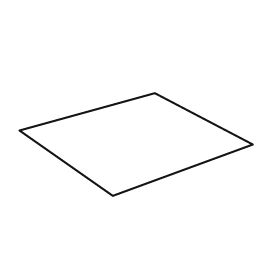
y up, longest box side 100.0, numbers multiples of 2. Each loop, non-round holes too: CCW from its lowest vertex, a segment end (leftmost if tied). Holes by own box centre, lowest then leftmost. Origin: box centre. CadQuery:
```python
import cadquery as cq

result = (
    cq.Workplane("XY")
    .moveTo(-10.0, -22.0)
    .lineTo(50.0, 0.0)
    .lineTo(8.0, 22.0)
    .lineTo(-50.0, 6.0)
    .close()
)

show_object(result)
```